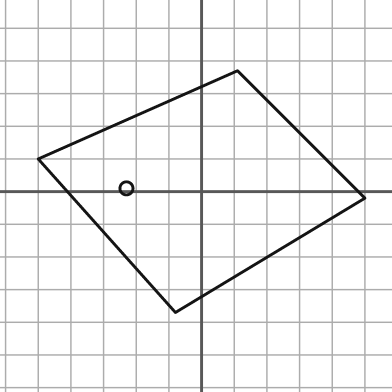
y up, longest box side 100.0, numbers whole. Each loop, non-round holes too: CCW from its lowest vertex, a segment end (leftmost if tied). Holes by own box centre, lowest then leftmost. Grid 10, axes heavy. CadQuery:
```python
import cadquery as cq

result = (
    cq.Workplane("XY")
    .moveTo(-8.0, -37.0)
    .lineTo(50.0, -2.0)
    .lineTo(11.0, 37.0)
    .lineTo(-50.0, 10.0)
    .close()
    .moveTo(-23.0, 1.0)
    .circle(2.0)
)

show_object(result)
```